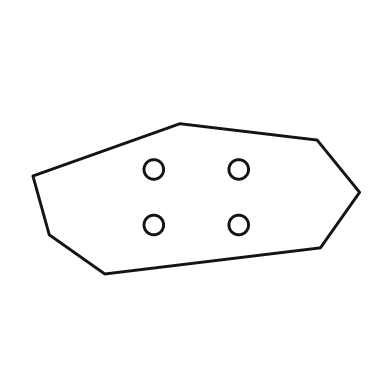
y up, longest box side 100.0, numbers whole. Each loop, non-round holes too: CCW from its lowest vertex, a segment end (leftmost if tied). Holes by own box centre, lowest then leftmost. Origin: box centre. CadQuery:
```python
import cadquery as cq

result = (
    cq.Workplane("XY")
    .moveTo(-28.0, -23.0)
    .lineTo(38.0, -15.0)
    .lineTo(50.0, 2.0)
    .lineTo(37.0, 18.0)
    .lineTo(-5.0, 23.0)
    .lineTo(-50.0, 7.0)
    .lineTo(-45.0, -11.0)
    .close()
    .moveTo(-13.0, -8.0)
    .circle(3.0)
    .moveTo(13.0, -8.0)
    .circle(3.0)
    .moveTo(-13.0, 9.0)
    .circle(3.0)
    .moveTo(13.0, 9.0)
    .circle(3.0)
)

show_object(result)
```